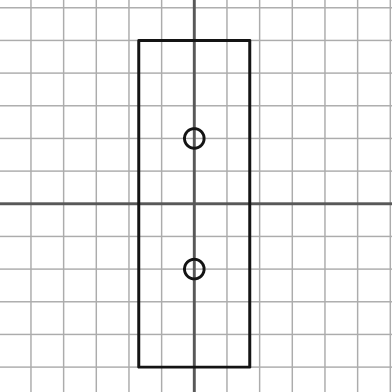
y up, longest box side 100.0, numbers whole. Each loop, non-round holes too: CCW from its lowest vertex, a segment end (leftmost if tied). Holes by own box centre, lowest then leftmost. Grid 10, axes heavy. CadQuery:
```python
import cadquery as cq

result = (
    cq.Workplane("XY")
    .moveTo(-17.0, -50.0)
    .lineTo(17.0, -50.0)
    .lineTo(17.0, 50.0)
    .lineTo(-17.0, 50.0)
    .close()
    .moveTo(0.0, -20.0)
    .circle(3.0)
    .moveTo(0.0, 20.0)
    .circle(3.0)
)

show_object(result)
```